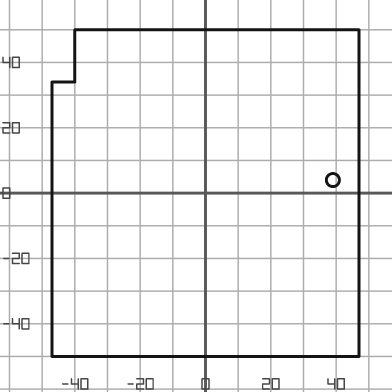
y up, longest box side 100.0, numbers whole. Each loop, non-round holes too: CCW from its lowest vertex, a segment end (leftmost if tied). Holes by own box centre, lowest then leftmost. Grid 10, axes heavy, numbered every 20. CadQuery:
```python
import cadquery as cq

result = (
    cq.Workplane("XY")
    .moveTo(-47.0, -50.0)
    .lineTo(47.0, -50.0)
    .lineTo(47.0, 50.0)
    .lineTo(-40.0, 50.0)
    .lineTo(-40.0, 34.0)
    .lineTo(-47.0, 34.0)
    .close()
    .moveTo(39.0, 4.0)
    .circle(2.0)
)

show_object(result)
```